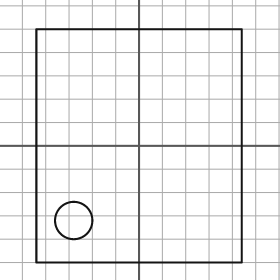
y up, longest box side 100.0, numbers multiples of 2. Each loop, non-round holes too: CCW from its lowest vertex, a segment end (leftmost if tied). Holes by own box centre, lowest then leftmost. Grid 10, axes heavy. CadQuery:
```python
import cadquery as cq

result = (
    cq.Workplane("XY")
    .moveTo(-44.0, -50.0)
    .lineTo(44.0, -50.0)
    .lineTo(44.0, 50.0)
    .lineTo(-44.0, 50.0)
    .close()
    .moveTo(-28.0, -32.0)
    .circle(8.0)
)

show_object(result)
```